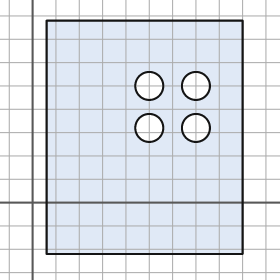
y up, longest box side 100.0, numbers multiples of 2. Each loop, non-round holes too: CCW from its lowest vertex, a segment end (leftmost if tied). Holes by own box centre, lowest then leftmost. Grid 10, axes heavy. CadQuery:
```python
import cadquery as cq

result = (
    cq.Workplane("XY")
    .moveTo(6.0, -22.0)
    .lineTo(90.0, -22.0)
    .lineTo(90.0, 78.0)
    .lineTo(6.0, 78.0)
    .close()
    .moveTo(50.0, 32.0)
    .circle(6.0)
    .moveTo(70.0, 32.0)
    .circle(6.0)
    .moveTo(50.0, 50.0)
    .circle(6.0)
    .moveTo(70.0, 50.0)
    .circle(6.0)
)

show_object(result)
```